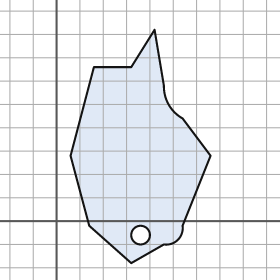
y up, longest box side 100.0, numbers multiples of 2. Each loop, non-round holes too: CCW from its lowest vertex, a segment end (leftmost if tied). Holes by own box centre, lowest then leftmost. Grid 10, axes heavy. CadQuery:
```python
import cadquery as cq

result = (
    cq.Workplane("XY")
    .moveTo(32.0, -18.0)
    .lineTo(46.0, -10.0)
    .threePointArc((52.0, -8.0), (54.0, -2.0))
    .lineTo(66.0, 28.0)
    .lineTo(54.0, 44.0)
    .threePointArc((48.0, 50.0), (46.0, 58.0))
    .lineTo(42.0, 82.0)
    .lineTo(32.0, 66.0)
    .lineTo(16.0, 66.0)
    .lineTo(6.0, 28.0)
    .lineTo(14.0, -2.0)
    .close()
    .moveTo(36.0, -6.0)
    .circle(4.0)
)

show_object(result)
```